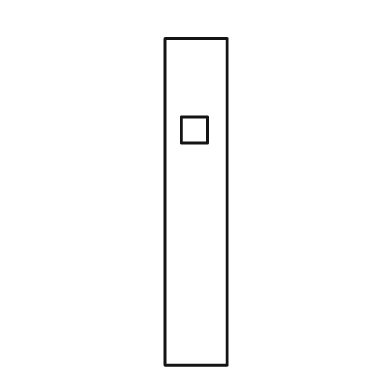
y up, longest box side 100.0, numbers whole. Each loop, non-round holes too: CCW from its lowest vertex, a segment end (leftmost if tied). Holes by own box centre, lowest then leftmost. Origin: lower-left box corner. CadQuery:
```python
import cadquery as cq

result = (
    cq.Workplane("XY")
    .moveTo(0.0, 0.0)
    .lineTo(19.0, 0.0)
    .lineTo(19.0, 100.0)
    .lineTo(0.0, 100.0)
    .close()
    .moveTo(5.0, 68.0)
    .lineTo(13.0, 68.0)
    .lineTo(13.0, 76.0)
    .lineTo(5.0, 76.0)
    .close()
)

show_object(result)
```